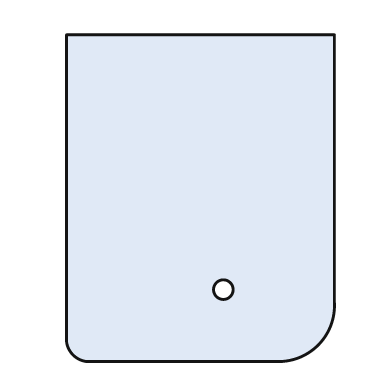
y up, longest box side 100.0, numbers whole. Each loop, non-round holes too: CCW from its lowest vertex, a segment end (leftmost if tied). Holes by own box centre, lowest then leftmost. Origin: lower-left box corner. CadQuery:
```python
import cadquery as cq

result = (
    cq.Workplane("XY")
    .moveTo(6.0, 0.0)
    .lineTo(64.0, 0.0)
    .threePointArc((77.0, 5.0), (82.0, 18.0))
    .lineTo(82.0, 100.0)
    .lineTo(0.0, 100.0)
    .lineTo(0.0, 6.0)
    .threePointArc((2.0, 2.0), (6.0, 0.0))
    .close()
    .moveTo(48.0, 22.0)
    .circle(3.0)
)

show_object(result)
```